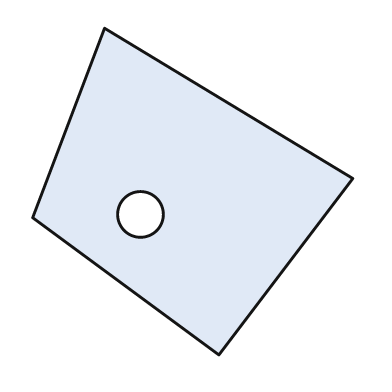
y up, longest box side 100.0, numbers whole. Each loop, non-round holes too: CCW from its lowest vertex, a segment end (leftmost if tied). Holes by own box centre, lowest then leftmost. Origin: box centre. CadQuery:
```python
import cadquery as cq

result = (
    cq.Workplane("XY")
    .moveTo(8.0, -50.0)
    .lineTo(49.0, 4.0)
    .lineTo(-27.0, 50.0)
    .lineTo(-49.0, -8.0)
    .close()
    .moveTo(-16.0, -7.0)
    .circle(7.0)
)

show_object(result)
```